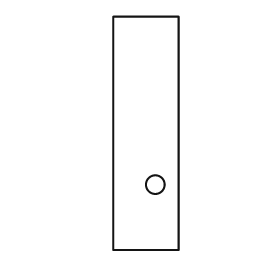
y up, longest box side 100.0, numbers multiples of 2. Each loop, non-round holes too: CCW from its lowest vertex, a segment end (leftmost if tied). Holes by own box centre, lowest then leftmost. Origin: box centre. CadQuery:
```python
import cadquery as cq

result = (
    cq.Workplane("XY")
    .moveTo(-14.0, -50.0)
    .lineTo(14.0, -50.0)
    .lineTo(14.0, 50.0)
    .lineTo(-14.0, 50.0)
    .close()
    .moveTo(4.0, -22.0)
    .circle(4.0)
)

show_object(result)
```